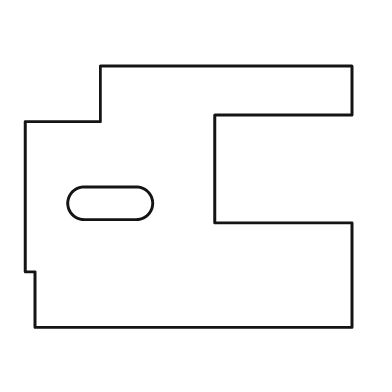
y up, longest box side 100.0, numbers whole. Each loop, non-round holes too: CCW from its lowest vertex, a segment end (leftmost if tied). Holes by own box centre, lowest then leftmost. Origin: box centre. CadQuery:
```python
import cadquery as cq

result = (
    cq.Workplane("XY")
    .moveTo(-47.0, -40.0)
    .lineTo(50.0, -40.0)
    .lineTo(50.0, -8.0)
    .lineTo(8.0, -8.0)
    .lineTo(8.0, 25.0)
    .lineTo(50.0, 25.0)
    .lineTo(50.0, 40.0)
    .lineTo(-27.0, 40.0)
    .lineTo(-27.0, 23.0)
    .lineTo(-50.0, 23.0)
    .lineTo(-50.0, -23.0)
    .lineTo(-47.0, -23.0)
    .close()
    .moveTo(-32.0, -7.0)
    .lineTo(-16.0, -7.0)
    .threePointArc((-11.0, -2.0), (-16.0, 3.0))
    .lineTo(-32.0, 3.0)
    .threePointArc((-37.0, -2.0), (-32.0, -7.0))
    .close()
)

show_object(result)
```